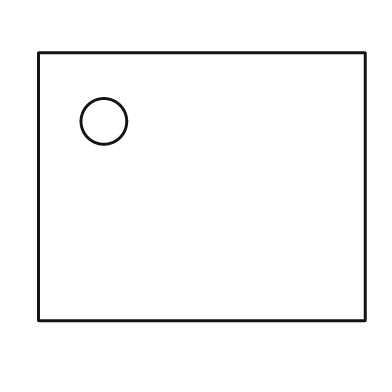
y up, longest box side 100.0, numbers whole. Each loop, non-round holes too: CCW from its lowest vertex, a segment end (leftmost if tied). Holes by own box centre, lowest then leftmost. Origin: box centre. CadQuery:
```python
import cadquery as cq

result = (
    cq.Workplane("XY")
    .moveTo(-50.0, -41.0)
    .lineTo(50.0, -41.0)
    .lineTo(50.0, 41.0)
    .lineTo(-50.0, 41.0)
    .close()
    .moveTo(-30.0, 20.0)
    .circle(7.0)
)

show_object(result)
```